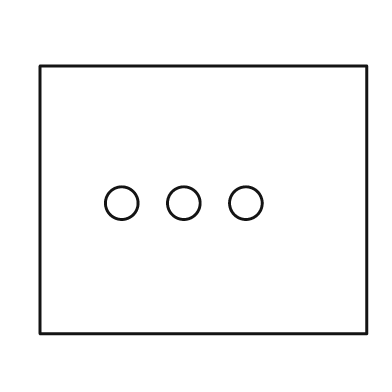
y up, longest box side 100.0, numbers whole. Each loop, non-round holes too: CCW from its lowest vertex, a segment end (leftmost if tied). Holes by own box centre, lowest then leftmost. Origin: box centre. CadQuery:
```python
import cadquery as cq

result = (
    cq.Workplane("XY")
    .moveTo(-50.0, -41.0)
    .lineTo(50.0, -41.0)
    .lineTo(50.0, 41.0)
    .lineTo(-50.0, 41.0)
    .close()
    .moveTo(-25.0, -1.0)
    .circle(5.0)
    .moveTo(-6.0, -1.0)
    .circle(5.0)
    .moveTo(13.0, -1.0)
    .circle(5.0)
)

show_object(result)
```